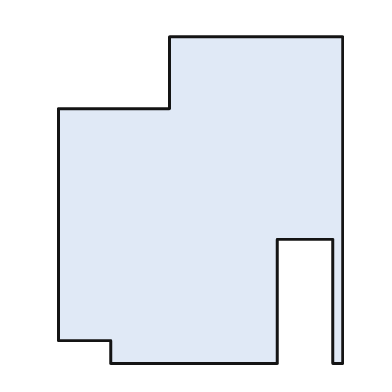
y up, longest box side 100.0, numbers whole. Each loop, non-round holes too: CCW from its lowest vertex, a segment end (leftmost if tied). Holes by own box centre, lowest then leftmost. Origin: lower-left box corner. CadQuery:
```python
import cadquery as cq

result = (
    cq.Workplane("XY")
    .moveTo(16.0, 0.0)
    .lineTo(67.0, 0.0)
    .lineTo(67.0, 38.0)
    .lineTo(84.0, 38.0)
    .lineTo(84.0, 0.0)
    .lineTo(87.0, 0.0)
    .lineTo(87.0, 100.0)
    .lineTo(34.0, 100.0)
    .lineTo(34.0, 78.0)
    .lineTo(0.0, 78.0)
    .lineTo(0.0, 7.0)
    .lineTo(16.0, 7.0)
    .close()
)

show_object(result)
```